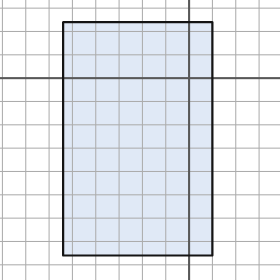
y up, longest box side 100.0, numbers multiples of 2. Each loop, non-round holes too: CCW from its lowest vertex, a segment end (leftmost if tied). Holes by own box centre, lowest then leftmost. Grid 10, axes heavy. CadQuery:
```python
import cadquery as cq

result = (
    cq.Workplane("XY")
    .moveTo(-54.0, -76.0)
    .lineTo(10.0, -76.0)
    .lineTo(10.0, 24.0)
    .lineTo(-54.0, 24.0)
    .close()
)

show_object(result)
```